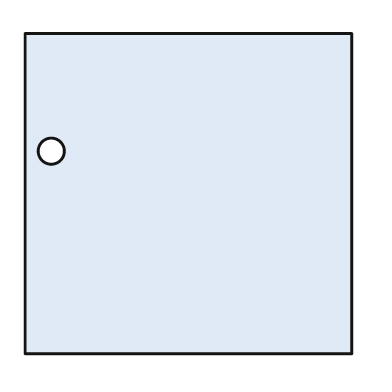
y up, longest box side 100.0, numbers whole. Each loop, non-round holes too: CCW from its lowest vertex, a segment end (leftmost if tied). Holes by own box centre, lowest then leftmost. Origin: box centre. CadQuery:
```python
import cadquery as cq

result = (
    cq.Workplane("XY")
    .moveTo(-50.0, -49.0)
    .lineTo(50.0, -49.0)
    .lineTo(50.0, 49.0)
    .lineTo(-50.0, 49.0)
    .close()
    .moveTo(-42.0, 13.0)
    .circle(4.0)
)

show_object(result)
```